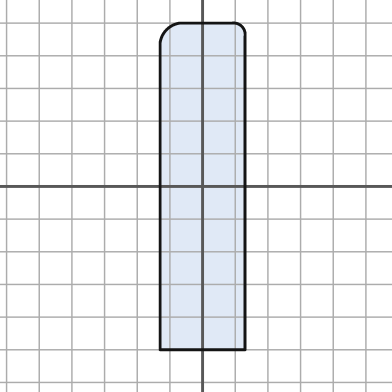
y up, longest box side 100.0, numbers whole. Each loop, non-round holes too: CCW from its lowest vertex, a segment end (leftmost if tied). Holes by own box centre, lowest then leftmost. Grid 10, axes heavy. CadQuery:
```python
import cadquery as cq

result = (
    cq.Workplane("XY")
    .moveTo(-13.0, -50.0)
    .lineTo(13.0, -50.0)
    .lineTo(13.0, 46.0)
    .threePointArc((12.0, 49.0), (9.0, 50.0))
    .lineTo(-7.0, 50.0)
    .threePointArc((-11.0, 48.0), (-13.0, 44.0))
    .close()
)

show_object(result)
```